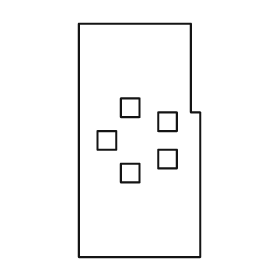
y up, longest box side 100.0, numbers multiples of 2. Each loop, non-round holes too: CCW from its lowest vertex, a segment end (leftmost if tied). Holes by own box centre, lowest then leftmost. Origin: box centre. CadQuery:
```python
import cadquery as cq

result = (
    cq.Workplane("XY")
    .moveTo(-26.0, -50.0)
    .lineTo(26.0, -50.0)
    .lineTo(26.0, 12.0)
    .lineTo(22.0, 12.0)
    .lineTo(22.0, 50.0)
    .lineTo(-26.0, 50.0)
    .close()
    .moveTo(-8.0, -18.0)
    .lineTo(0.0, -18.0)
    .lineTo(0.0, -10.0)
    .lineTo(-8.0, -10.0)
    .close()
    .moveTo(8.0, -12.0)
    .lineTo(16.0, -12.0)
    .lineTo(16.0, -4.0)
    .lineTo(8.0, -4.0)
    .close()
    .moveTo(-18.0, -4.0)
    .lineTo(-10.0, -4.0)
    .lineTo(-10.0, 4.0)
    .lineTo(-18.0, 4.0)
    .close()
    .moveTo(8.0, 4.0)
    .lineTo(16.0, 4.0)
    .lineTo(16.0, 12.0)
    .lineTo(8.0, 12.0)
    .close()
    .moveTo(-8.0, 10.0)
    .lineTo(0.0, 10.0)
    .lineTo(0.0, 18.0)
    .lineTo(-8.0, 18.0)
    .close()
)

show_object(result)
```